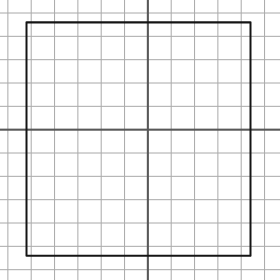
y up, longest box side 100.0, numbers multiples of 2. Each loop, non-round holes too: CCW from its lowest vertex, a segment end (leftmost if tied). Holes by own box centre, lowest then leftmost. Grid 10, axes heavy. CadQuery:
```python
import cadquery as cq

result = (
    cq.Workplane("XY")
    .moveTo(-52.0, -54.0)
    .lineTo(44.0, -54.0)
    .lineTo(44.0, 46.0)
    .lineTo(-52.0, 46.0)
    .close()
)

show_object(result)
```